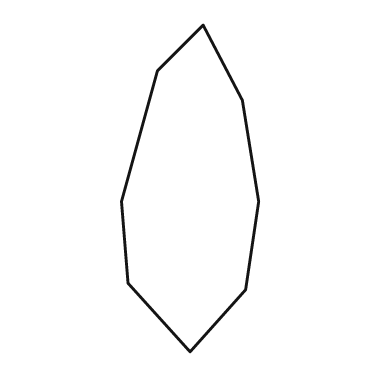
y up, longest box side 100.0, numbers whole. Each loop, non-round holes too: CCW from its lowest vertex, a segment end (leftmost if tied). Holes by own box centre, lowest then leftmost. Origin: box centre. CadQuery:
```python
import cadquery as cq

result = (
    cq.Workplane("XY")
    .moveTo(0.0, -50.0)
    .lineTo(17.0, -31.0)
    .lineTo(21.0, -4.0)
    .lineTo(16.0, 27.0)
    .lineTo(4.0, 50.0)
    .lineTo(-10.0, 36.0)
    .lineTo(-21.0, -4.0)
    .lineTo(-19.0, -29.0)
    .close()
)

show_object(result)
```